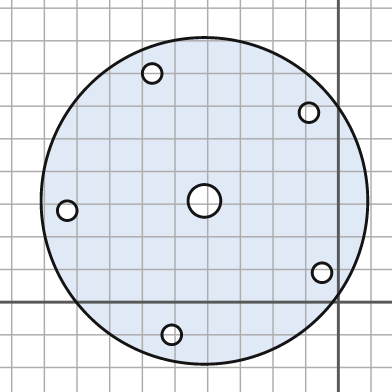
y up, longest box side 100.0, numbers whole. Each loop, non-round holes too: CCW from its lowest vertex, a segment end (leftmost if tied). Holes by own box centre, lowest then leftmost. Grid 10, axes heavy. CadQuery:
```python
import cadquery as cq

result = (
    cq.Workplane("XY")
    .moveTo(-41.0, 31.0)
    .circle(50.0)
    .moveTo(-51.0, -10.0)
    .circle(3.0)
    .moveTo(-5.0, 9.0)
    .circle(3.0)
    .moveTo(-83.0, 28.0)
    .circle(3.0)
    .moveTo(-41.0, 31.0)
    .circle(5.0)
    .moveTo(-9.0, 58.0)
    .circle(3.0)
    .moveTo(-57.0, 70.0)
    .circle(3.0)
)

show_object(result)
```